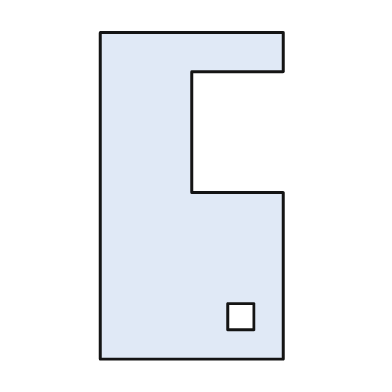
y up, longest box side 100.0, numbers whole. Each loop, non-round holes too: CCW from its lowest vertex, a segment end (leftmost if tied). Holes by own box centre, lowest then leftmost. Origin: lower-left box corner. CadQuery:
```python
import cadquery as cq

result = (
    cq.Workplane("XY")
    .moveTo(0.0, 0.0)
    .lineTo(56.0, 0.0)
    .lineTo(56.0, 51.0)
    .lineTo(28.0, 51.0)
    .lineTo(28.0, 88.0)
    .lineTo(56.0, 88.0)
    .lineTo(56.0, 100.0)
    .lineTo(0.0, 100.0)
    .close()
    .moveTo(39.0, 9.0)
    .lineTo(47.0, 9.0)
    .lineTo(47.0, 17.0)
    .lineTo(39.0, 17.0)
    .close()
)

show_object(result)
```